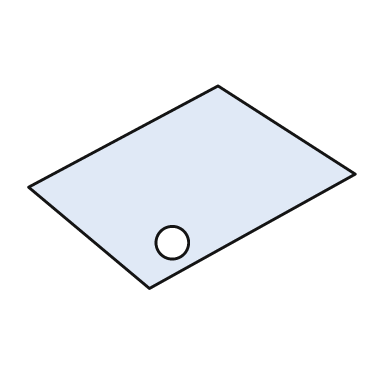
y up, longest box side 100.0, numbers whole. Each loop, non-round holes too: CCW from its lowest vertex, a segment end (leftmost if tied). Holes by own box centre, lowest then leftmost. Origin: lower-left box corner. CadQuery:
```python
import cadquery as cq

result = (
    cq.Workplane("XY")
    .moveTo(37.0, 0.0)
    .lineTo(100.0, 35.0)
    .lineTo(58.0, 62.0)
    .lineTo(0.0, 31.0)
    .close()
    .moveTo(44.0, 14.0)
    .circle(5.0)
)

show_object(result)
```